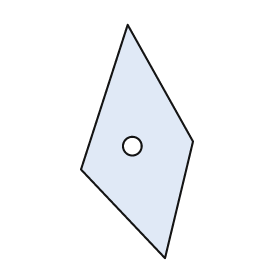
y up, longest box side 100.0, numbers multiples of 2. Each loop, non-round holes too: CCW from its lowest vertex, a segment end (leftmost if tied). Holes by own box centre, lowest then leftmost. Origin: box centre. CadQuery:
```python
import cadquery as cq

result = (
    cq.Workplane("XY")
    .moveTo(12.0, -50.0)
    .lineTo(24.0, 0.0)
    .lineTo(-4.0, 50.0)
    .lineTo(-24.0, -12.0)
    .close()
    .moveTo(-2.0, -2.0)
    .circle(4.0)
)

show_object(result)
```